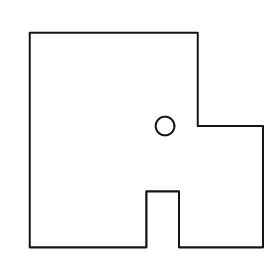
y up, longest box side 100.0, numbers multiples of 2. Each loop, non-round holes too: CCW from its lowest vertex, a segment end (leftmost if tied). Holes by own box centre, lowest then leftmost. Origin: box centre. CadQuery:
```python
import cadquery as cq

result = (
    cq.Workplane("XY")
    .moveTo(-50.0, -46.0)
    .lineTo(0.0, -46.0)
    .lineTo(0.0, -22.0)
    .lineTo(14.0, -22.0)
    .lineTo(14.0, -46.0)
    .lineTo(50.0, -46.0)
    .lineTo(50.0, 6.0)
    .lineTo(22.0, 6.0)
    .lineTo(22.0, 46.0)
    .lineTo(-50.0, 46.0)
    .close()
    .moveTo(8.0, 6.0)
    .circle(4.0)
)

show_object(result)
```